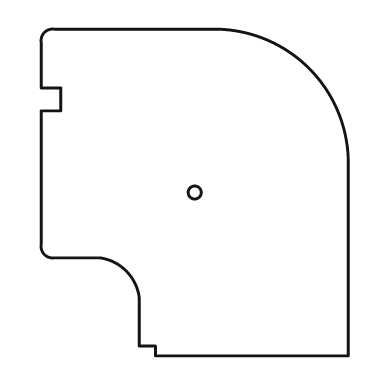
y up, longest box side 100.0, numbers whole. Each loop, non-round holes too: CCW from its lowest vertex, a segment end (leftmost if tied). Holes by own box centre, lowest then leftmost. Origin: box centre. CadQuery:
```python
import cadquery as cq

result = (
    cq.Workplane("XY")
    .moveTo(-12.0, -50.0)
    .lineTo(47.0, -50.0)
    .lineTo(47.0, 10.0)
    .threePointArc((35.0, 38.0), (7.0, 50.0))
    .lineTo(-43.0, 50.0)
    .threePointArc((-46.0, 49.0), (-47.0, 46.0))
    .lineTo(-47.0, 32.0)
    .lineTo(-41.0, 32.0)
    .lineTo(-41.0, 25.0)
    .lineTo(-47.0, 25.0)
    .lineTo(-47.0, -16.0)
    .threePointArc((-46.0, -19.0), (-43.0, -20.0))
    .lineTo(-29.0, -20.0)
    .threePointArc((-21.0, -24.0), (-17.0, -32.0))
    .lineTo(-17.0, -47.0)
    .lineTo(-12.0, -47.0)
    .close()
    .moveTo(0.0, 0.0)
    .circle(2.0)
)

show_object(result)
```